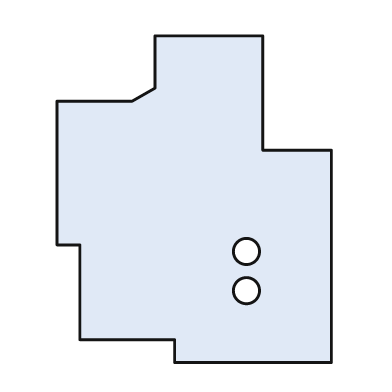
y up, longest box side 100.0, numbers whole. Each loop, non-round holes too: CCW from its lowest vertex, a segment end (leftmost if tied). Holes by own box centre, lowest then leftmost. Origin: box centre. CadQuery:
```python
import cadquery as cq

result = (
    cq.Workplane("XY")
    .moveTo(-6.0, -50.0)
    .lineTo(42.0, -50.0)
    .lineTo(42.0, 15.0)
    .lineTo(21.0, 15.0)
    .lineTo(21.0, 50.0)
    .lineTo(-12.0, 50.0)
    .lineTo(-12.0, 34.0)
    .lineTo(-19.0, 30.0)
    .lineTo(-42.0, 30.0)
    .lineTo(-42.0, -14.0)
    .lineTo(-35.0, -14.0)
    .lineTo(-35.0, -43.0)
    .lineTo(-6.0, -43.0)
    .close()
    .moveTo(16.0, -28.0)
    .circle(4.0)
    .moveTo(16.0, -16.0)
    .circle(4.0)
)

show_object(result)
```